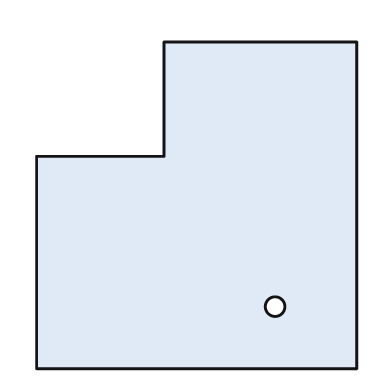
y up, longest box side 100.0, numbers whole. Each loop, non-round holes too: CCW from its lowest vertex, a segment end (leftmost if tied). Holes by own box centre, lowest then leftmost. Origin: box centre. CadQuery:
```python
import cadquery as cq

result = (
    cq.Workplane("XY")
    .moveTo(-49.0, -50.0)
    .lineTo(49.0, -50.0)
    .lineTo(49.0, 50.0)
    .lineTo(-10.0, 50.0)
    .lineTo(-10.0, 15.0)
    .lineTo(-49.0, 15.0)
    .close()
    .moveTo(24.0, -31.0)
    .circle(3.0)
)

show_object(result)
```